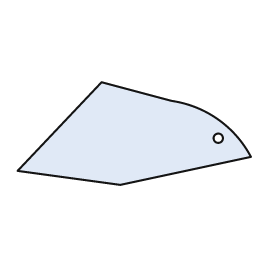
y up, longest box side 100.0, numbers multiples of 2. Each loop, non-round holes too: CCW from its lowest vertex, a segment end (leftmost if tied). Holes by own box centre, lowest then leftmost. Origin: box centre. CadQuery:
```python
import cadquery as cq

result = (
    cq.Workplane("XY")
    .moveTo(-6.0, -22.0)
    .lineTo(50.0, -10.0)
    .threePointArc((36.0, 6.0), (16.0, 14.0))
    .lineTo(-14.0, 22.0)
    .lineTo(-50.0, -16.0)
    .close()
    .moveTo(36.0, -2.0)
    .circle(2.0)
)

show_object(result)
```